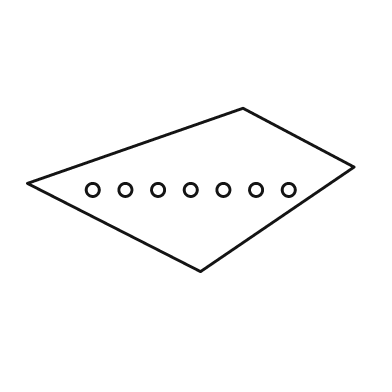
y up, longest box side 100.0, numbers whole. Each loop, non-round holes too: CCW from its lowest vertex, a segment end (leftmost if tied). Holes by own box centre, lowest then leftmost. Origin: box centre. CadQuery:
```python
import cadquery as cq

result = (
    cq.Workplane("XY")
    .moveTo(3.0, -25.0)
    .lineTo(50.0, 7.0)
    .lineTo(16.0, 25.0)
    .lineTo(-50.0, 2.0)
    .close()
    .moveTo(-30.0, 0.0)
    .circle(2.0)
    .moveTo(-20.0, 0.0)
    .circle(2.0)
    .moveTo(-10.0, 0.0)
    .circle(2.0)
    .moveTo(0.0, 0.0)
    .circle(2.0)
    .moveTo(10.0, 0.0)
    .circle(2.0)
    .moveTo(20.0, 0.0)
    .circle(2.0)
    .moveTo(30.0, 0.0)
    .circle(2.0)
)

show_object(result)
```